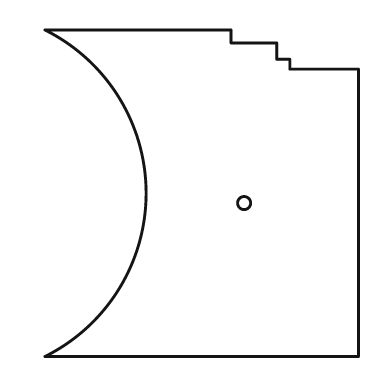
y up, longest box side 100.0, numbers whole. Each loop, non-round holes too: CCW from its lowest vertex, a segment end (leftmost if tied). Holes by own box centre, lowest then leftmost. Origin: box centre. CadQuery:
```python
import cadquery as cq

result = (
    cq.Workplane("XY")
    .moveTo(-48.0, -50.0)
    .lineTo(48.0, -50.0)
    .lineTo(48.0, 38.0)
    .lineTo(27.0, 38.0)
    .lineTo(27.0, 41.0)
    .lineTo(23.0, 41.0)
    .lineTo(23.0, 46.0)
    .lineTo(9.0, 46.0)
    .lineTo(9.0, 50.0)
    .lineTo(-48.0, 50.0)
    .threePointArc((-17.0, 0.0), (-48.0, -50.0))
    .close()
    .moveTo(13.0, -3.0)
    .circle(2.0)
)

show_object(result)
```